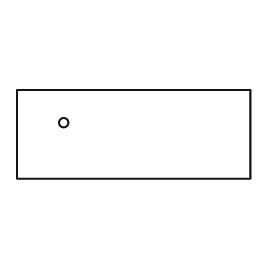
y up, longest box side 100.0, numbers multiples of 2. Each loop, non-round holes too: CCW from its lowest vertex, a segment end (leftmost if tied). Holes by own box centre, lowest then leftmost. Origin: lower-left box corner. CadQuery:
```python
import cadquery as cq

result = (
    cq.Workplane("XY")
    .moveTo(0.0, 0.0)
    .lineTo(100.0, 0.0)
    .lineTo(100.0, 38.0)
    .lineTo(0.0, 38.0)
    .close()
    .moveTo(20.0, 24.0)
    .circle(2.0)
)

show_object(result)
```